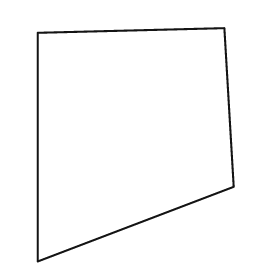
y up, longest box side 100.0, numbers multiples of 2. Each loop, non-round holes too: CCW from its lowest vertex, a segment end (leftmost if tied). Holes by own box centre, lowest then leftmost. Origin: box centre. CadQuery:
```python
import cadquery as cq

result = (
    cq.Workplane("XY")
    .moveTo(-42.0, -50.0)
    .lineTo(42.0, -18.0)
    .lineTo(38.0, 50.0)
    .lineTo(-42.0, 48.0)
    .close()
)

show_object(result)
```